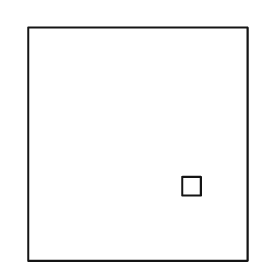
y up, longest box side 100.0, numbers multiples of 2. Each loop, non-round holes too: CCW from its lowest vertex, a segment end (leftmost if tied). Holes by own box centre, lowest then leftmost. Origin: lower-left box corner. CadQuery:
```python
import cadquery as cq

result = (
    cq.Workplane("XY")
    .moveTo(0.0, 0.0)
    .lineTo(94.0, 0.0)
    .lineTo(94.0, 100.0)
    .lineTo(0.0, 100.0)
    .close()
    .moveTo(66.0, 28.0)
    .lineTo(74.0, 28.0)
    .lineTo(74.0, 36.0)
    .lineTo(66.0, 36.0)
    .close()
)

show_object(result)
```